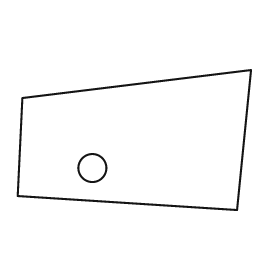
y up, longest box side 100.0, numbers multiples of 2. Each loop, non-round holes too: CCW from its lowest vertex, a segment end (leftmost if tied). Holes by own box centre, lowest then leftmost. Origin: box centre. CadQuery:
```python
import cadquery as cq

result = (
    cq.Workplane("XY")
    .moveTo(44.0, -30.0)
    .lineTo(50.0, 30.0)
    .lineTo(-48.0, 18.0)
    .lineTo(-50.0, -24.0)
    .close()
    .moveTo(-18.0, -12.0)
    .circle(6.0)
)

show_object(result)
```